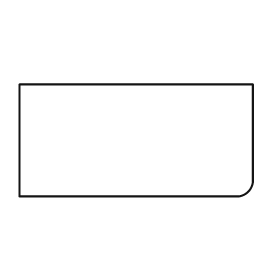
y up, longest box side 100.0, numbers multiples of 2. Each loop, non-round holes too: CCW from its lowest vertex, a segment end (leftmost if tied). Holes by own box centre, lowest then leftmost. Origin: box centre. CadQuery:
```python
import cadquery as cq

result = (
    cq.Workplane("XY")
    .moveTo(-50.0, -24.0)
    .lineTo(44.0, -24.0)
    .threePointArc((48.0, -22.0), (50.0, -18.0))
    .lineTo(50.0, 24.0)
    .lineTo(-50.0, 24.0)
    .close()
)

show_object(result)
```